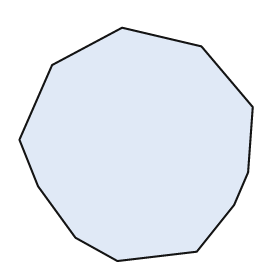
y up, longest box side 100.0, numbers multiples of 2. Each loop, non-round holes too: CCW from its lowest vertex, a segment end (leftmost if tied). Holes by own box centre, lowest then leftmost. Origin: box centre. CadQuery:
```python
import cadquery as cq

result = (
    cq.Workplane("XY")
    .moveTo(-8.0, -50.0)
    .lineTo(26.0, -46.0)
    .lineTo(42.0, -26.0)
    .lineTo(48.0, -12.0)
    .lineTo(50.0, 16.0)
    .lineTo(28.0, 42.0)
    .lineTo(-6.0, 50.0)
    .lineTo(-36.0, 34.0)
    .lineTo(-50.0, 2.0)
    .lineTo(-42.0, -18.0)
    .lineTo(-26.0, -40.0)
    .close()
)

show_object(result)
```